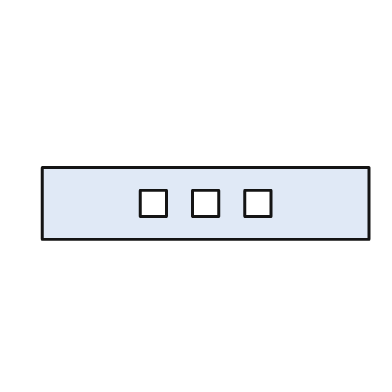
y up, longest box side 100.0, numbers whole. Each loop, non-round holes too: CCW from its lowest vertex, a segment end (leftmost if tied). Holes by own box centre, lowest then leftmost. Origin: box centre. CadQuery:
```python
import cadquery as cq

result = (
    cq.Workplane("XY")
    .moveTo(-50.0, -11.0)
    .lineTo(50.0, -11.0)
    .lineTo(50.0, 11.0)
    .lineTo(-50.0, 11.0)
    .close()
    .moveTo(-20.0, -4.0)
    .lineTo(-12.0, -4.0)
    .lineTo(-12.0, 4.0)
    .lineTo(-20.0, 4.0)
    .close()
    .moveTo(-4.0, -4.0)
    .lineTo(4.0, -4.0)
    .lineTo(4.0, 4.0)
    .lineTo(-4.0, 4.0)
    .close()
    .moveTo(12.0, -4.0)
    .lineTo(20.0, -4.0)
    .lineTo(20.0, 4.0)
    .lineTo(12.0, 4.0)
    .close()
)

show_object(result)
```